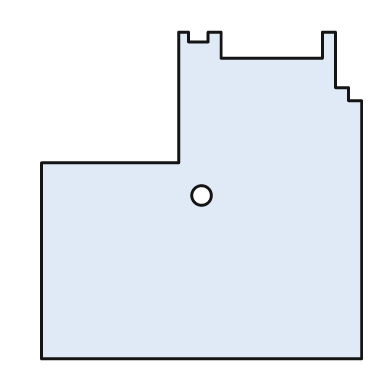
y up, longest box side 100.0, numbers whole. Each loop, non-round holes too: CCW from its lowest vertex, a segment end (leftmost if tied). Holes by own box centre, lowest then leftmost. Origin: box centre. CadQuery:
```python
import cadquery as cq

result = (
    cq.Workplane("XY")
    .moveTo(-49.0, -50.0)
    .lineTo(49.0, -50.0)
    .lineTo(49.0, 29.0)
    .lineTo(45.0, 29.0)
    .lineTo(45.0, 33.0)
    .lineTo(41.0, 33.0)
    .lineTo(41.0, 50.0)
    .lineTo(37.0, 50.0)
    .lineTo(37.0, 42.0)
    .lineTo(6.0, 42.0)
    .lineTo(6.0, 50.0)
    .lineTo(2.0, 50.0)
    .lineTo(2.0, 47.0)
    .lineTo(-4.0, 47.0)
    .lineTo(-4.0, 50.0)
    .lineTo(-7.0, 50.0)
    .lineTo(-7.0, 10.0)
    .lineTo(-49.0, 10.0)
    .close()
    .moveTo(0.0, 0.0)
    .circle(3.0)
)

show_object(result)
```